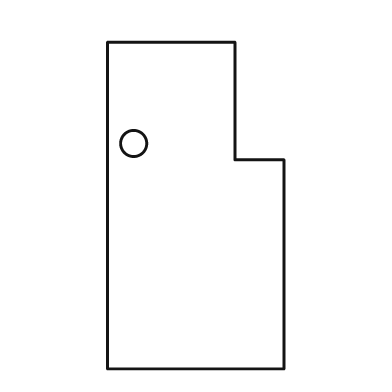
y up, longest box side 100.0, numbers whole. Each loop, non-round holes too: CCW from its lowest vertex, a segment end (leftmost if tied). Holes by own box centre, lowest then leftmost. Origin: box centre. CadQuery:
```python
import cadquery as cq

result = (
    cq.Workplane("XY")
    .moveTo(-27.0, -50.0)
    .lineTo(27.0, -50.0)
    .lineTo(27.0, 14.0)
    .lineTo(12.0, 14.0)
    .lineTo(12.0, 50.0)
    .lineTo(-27.0, 50.0)
    .close()
    .moveTo(-19.0, 19.0)
    .circle(4.0)
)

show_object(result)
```